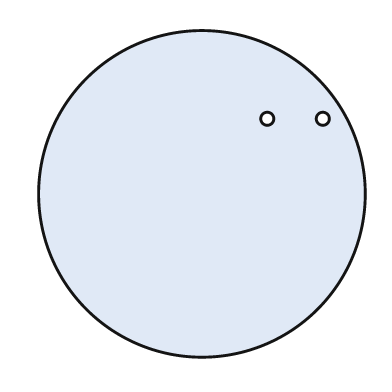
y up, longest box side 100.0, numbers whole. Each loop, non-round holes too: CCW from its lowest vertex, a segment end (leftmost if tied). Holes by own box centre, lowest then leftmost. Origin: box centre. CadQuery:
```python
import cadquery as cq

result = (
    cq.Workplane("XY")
    .moveTo(0.0, 0.0)
    .circle(50.0)
    .moveTo(20.0, 23.0)
    .circle(2.0)
    .moveTo(37.0, 23.0)
    .circle(2.0)
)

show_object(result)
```